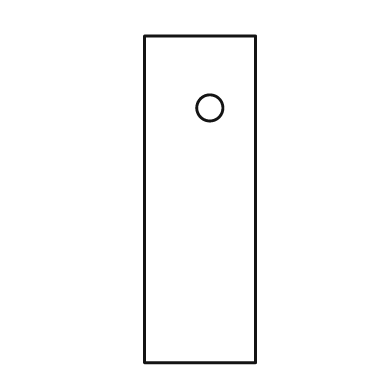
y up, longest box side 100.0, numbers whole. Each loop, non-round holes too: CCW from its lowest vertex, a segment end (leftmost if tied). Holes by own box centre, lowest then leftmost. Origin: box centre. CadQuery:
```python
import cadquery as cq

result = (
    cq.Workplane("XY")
    .moveTo(-17.0, -50.0)
    .lineTo(17.0, -50.0)
    .lineTo(17.0, 50.0)
    .lineTo(-17.0, 50.0)
    .close()
    .moveTo(3.0, 28.0)
    .circle(4.0)
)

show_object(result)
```